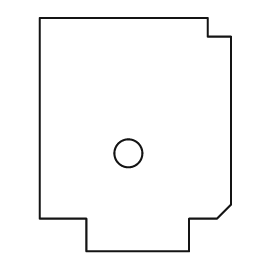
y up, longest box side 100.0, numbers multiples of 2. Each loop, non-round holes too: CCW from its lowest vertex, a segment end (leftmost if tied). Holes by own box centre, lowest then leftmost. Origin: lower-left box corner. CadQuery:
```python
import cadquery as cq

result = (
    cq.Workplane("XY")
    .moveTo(20.0, 0.0)
    .lineTo(64.0, 0.0)
    .lineTo(64.0, 14.0)
    .lineTo(76.0, 14.0)
    .lineTo(82.0, 20.0)
    .lineTo(82.0, 92.0)
    .lineTo(72.0, 92.0)
    .lineTo(72.0, 100.0)
    .lineTo(0.0, 100.0)
    .lineTo(0.0, 14.0)
    .lineTo(20.0, 14.0)
    .close()
    .moveTo(38.0, 42.0)
    .circle(6.0)
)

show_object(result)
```